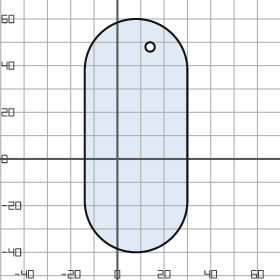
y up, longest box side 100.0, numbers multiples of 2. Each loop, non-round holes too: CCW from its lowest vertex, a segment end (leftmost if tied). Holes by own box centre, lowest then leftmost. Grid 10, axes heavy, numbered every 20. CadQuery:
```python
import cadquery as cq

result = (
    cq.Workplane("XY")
    .moveTo(-14.0, -18.0)
    .threePointArc((8.0, -40.0), (30.0, -18.0))
    .lineTo(30.0, 38.0)
    .threePointArc((8.0, 60.0), (-14.0, 38.0))
    .close()
    .moveTo(14.0, 48.0)
    .circle(2.0)
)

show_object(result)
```